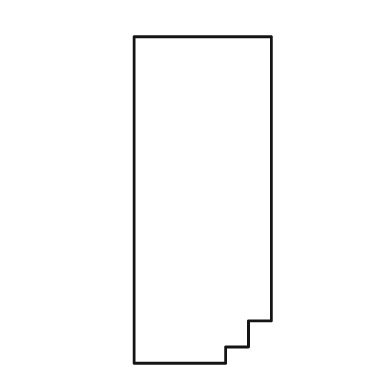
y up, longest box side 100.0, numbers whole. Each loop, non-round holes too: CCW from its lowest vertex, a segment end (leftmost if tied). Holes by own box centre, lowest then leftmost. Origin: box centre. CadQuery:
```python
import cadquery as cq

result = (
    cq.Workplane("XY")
    .moveTo(-21.0, -50.0)
    .lineTo(7.0, -50.0)
    .lineTo(7.0, -45.0)
    .lineTo(14.0, -45.0)
    .lineTo(14.0, -37.0)
    .lineTo(21.0, -37.0)
    .lineTo(21.0, 50.0)
    .lineTo(-21.0, 50.0)
    .close()
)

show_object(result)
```